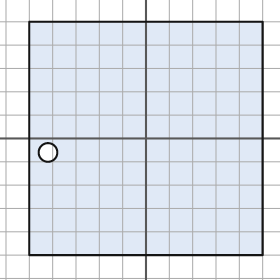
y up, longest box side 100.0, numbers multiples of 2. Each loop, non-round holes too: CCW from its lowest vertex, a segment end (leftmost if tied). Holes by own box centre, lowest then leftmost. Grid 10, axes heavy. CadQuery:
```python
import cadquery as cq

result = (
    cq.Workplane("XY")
    .moveTo(-50.0, -50.0)
    .lineTo(50.0, -50.0)
    .lineTo(50.0, 50.0)
    .lineTo(-50.0, 50.0)
    .close()
    .moveTo(-42.0, -6.0)
    .circle(4.0)
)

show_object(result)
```